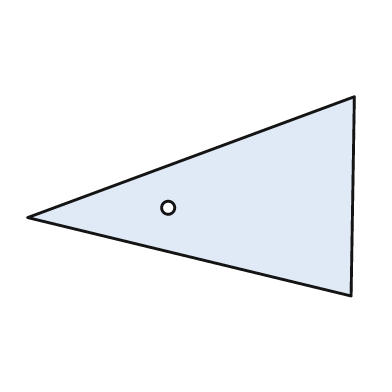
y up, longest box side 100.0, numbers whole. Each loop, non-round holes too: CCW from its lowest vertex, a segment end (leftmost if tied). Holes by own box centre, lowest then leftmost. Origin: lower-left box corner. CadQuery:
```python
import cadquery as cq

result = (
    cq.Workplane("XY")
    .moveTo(99.0, 0.0)
    .lineTo(100.0, 61.0)
    .lineTo(0.0, 24.0)
    .close()
    .moveTo(43.0, 27.0)
    .circle(2.0)
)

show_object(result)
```